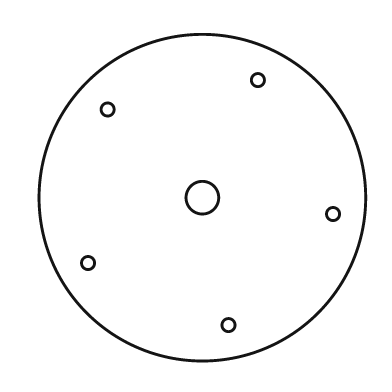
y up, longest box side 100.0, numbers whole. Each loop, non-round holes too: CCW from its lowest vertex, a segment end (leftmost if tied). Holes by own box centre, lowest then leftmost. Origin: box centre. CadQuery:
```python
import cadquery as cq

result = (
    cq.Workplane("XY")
    .moveTo(0.0, 0.0)
    .circle(50.0)
    .moveTo(8.0, -39.0)
    .circle(2.0)
    .moveTo(-35.0, -20.0)
    .circle(2.0)
    .moveTo(40.0, -5.0)
    .circle(2.0)
    .moveTo(0.0, 0.0)
    .circle(5.0)
    .moveTo(-29.0, 27.0)
    .circle(2.0)
    .moveTo(17.0, 36.0)
    .circle(2.0)
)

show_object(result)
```